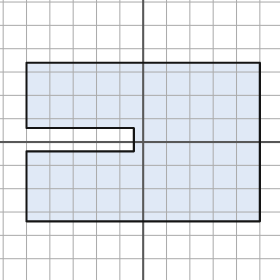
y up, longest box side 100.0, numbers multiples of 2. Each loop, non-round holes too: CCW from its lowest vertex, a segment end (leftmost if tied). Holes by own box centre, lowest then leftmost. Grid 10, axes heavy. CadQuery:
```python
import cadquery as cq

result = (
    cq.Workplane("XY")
    .moveTo(-50.0, -34.0)
    .lineTo(50.0, -34.0)
    .lineTo(50.0, 34.0)
    .lineTo(-50.0, 34.0)
    .lineTo(-50.0, 6.0)
    .lineTo(-4.0, 6.0)
    .lineTo(-4.0, -4.0)
    .lineTo(-50.0, -4.0)
    .close()
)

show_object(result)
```